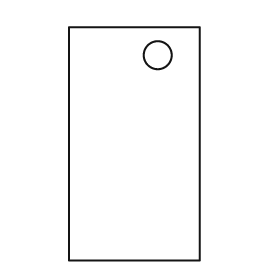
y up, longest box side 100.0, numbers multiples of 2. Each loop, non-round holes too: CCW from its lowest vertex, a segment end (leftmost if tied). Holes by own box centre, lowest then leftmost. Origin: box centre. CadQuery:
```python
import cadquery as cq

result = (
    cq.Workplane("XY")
    .moveTo(-28.0, -50.0)
    .lineTo(28.0, -50.0)
    .lineTo(28.0, 50.0)
    .lineTo(-28.0, 50.0)
    .close()
    .moveTo(10.0, 38.0)
    .circle(6.0)
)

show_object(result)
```